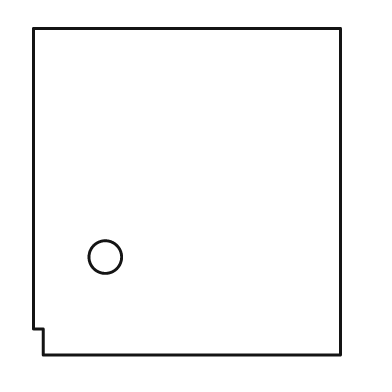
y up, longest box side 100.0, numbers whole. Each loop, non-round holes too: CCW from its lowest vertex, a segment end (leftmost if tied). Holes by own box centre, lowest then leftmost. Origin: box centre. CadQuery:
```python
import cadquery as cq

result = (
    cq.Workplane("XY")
    .moveTo(-44.0, -50.0)
    .lineTo(47.0, -50.0)
    .lineTo(47.0, 50.0)
    .lineTo(-47.0, 50.0)
    .lineTo(-47.0, -42.0)
    .lineTo(-44.0, -42.0)
    .close()
    .moveTo(-25.0, -20.0)
    .circle(5.0)
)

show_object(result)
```